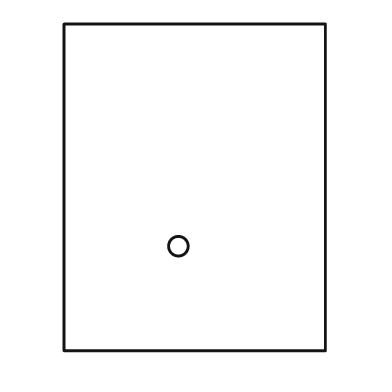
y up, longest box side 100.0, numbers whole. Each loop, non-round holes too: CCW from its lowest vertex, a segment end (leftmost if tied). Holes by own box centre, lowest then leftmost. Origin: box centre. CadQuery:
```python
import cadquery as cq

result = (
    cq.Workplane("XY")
    .moveTo(-40.0, -50.0)
    .lineTo(40.0, -50.0)
    .lineTo(40.0, 50.0)
    .lineTo(-40.0, 50.0)
    .close()
    .moveTo(-5.0, -18.0)
    .circle(3.0)
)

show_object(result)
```